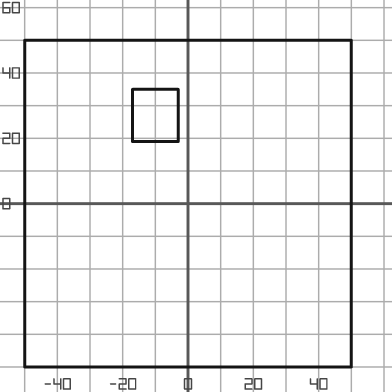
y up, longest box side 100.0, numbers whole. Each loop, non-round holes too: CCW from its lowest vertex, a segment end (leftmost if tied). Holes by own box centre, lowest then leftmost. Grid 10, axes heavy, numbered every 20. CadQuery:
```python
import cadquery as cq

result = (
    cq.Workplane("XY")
    .moveTo(-50.0, -50.0)
    .lineTo(50.0, -50.0)
    .lineTo(50.0, 50.0)
    .lineTo(-50.0, 50.0)
    .close()
    .moveTo(-17.0, 19.0)
    .lineTo(-3.0, 19.0)
    .lineTo(-3.0, 35.0)
    .lineTo(-17.0, 35.0)
    .close()
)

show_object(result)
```